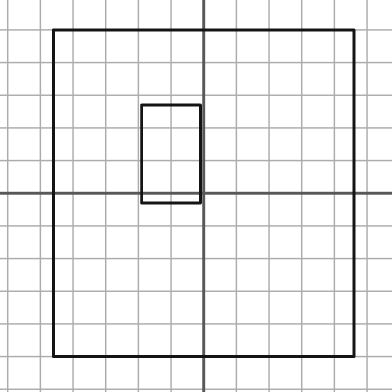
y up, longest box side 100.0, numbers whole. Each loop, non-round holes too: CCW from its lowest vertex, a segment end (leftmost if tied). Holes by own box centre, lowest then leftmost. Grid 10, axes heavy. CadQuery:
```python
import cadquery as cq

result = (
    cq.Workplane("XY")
    .moveTo(-46.0, -50.0)
    .lineTo(46.0, -50.0)
    .lineTo(46.0, 50.0)
    .lineTo(-46.0, 50.0)
    .close()
    .moveTo(-19.0, -3.0)
    .lineTo(-1.0, -3.0)
    .lineTo(-1.0, 27.0)
    .lineTo(-19.0, 27.0)
    .close()
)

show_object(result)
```